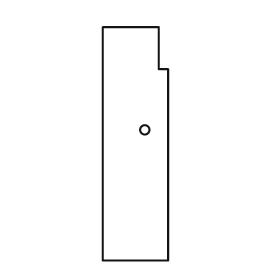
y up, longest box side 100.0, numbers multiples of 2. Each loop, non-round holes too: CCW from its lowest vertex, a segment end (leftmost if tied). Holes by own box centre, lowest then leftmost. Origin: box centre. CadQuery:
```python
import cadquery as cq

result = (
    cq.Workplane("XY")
    .moveTo(-14.0, -50.0)
    .lineTo(14.0, -50.0)
    .lineTo(14.0, 32.0)
    .lineTo(10.0, 32.0)
    .lineTo(10.0, 50.0)
    .lineTo(-14.0, 50.0)
    .close()
    .moveTo(4.0, 6.0)
    .circle(2.0)
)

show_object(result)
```